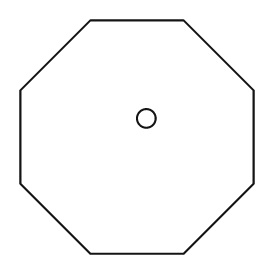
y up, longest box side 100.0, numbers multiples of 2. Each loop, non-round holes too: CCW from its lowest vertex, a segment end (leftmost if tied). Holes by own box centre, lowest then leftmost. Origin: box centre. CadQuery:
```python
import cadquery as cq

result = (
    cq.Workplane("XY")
    .moveTo(-20.0, -50.0)
    .lineTo(20.0, -50.0)
    .lineTo(50.0, -20.0)
    .lineTo(50.0, 20.0)
    .lineTo(20.0, 50.0)
    .lineTo(-20.0, 50.0)
    .lineTo(-50.0, 20.0)
    .lineTo(-50.0, -20.0)
    .close()
    .moveTo(4.0, 8.0)
    .circle(4.0)
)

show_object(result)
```